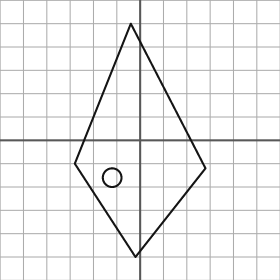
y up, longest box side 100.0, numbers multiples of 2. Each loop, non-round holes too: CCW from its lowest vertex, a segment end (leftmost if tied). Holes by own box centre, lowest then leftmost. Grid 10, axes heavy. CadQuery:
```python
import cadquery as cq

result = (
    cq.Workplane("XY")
    .moveTo(-2.0, -50.0)
    .lineTo(28.0, -12.0)
    .lineTo(-4.0, 50.0)
    .lineTo(-28.0, -10.0)
    .close()
    .moveTo(-12.0, -16.0)
    .circle(4.0)
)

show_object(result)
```